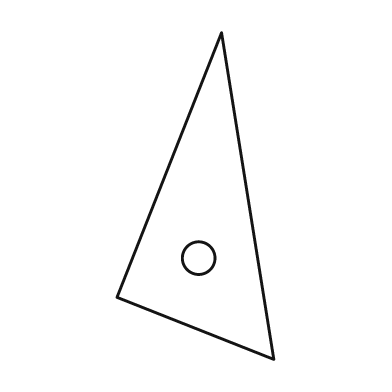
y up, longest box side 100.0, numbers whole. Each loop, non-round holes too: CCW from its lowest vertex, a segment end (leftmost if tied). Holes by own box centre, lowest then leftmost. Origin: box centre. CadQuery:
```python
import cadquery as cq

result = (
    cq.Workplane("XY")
    .moveTo(24.0, -50.0)
    .lineTo(8.0, 50.0)
    .lineTo(-24.0, -31.0)
    .close()
    .moveTo(1.0, -19.0)
    .circle(5.0)
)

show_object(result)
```